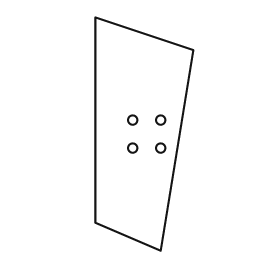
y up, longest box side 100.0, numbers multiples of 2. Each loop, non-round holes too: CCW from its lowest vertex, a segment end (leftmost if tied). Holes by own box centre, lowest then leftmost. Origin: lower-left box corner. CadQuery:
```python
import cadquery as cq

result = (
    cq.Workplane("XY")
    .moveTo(28.0, 0.0)
    .lineTo(42.0, 86.0)
    .lineTo(0.0, 100.0)
    .lineTo(0.0, 12.0)
    .close()
    .moveTo(16.0, 44.0)
    .circle(2.0)
    .moveTo(28.0, 44.0)
    .circle(2.0)
    .moveTo(16.0, 56.0)
    .circle(2.0)
    .moveTo(28.0, 56.0)
    .circle(2.0)
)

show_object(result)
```